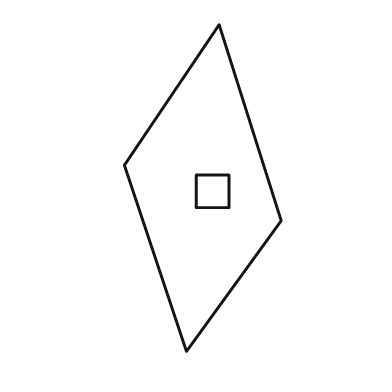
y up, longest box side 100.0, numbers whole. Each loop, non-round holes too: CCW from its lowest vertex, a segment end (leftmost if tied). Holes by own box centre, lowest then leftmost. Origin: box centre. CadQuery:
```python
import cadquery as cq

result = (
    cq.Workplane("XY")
    .moveTo(-5.0, -50.0)
    .lineTo(24.0, -10.0)
    .lineTo(5.0, 50.0)
    .lineTo(-24.0, 7.0)
    .close()
    .moveTo(-2.0, -6.0)
    .lineTo(8.0, -6.0)
    .lineTo(8.0, 4.0)
    .lineTo(-2.0, 4.0)
    .close()
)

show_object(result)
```